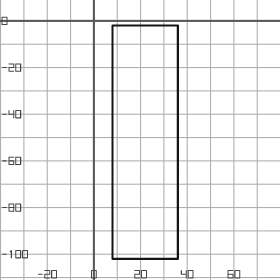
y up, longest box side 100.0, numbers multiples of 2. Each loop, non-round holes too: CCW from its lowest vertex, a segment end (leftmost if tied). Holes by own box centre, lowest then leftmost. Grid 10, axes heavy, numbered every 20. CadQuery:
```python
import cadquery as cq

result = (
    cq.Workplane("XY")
    .moveTo(8.0, -102.0)
    .lineTo(36.0, -102.0)
    .lineTo(36.0, -2.0)
    .lineTo(8.0, -2.0)
    .close()
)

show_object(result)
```